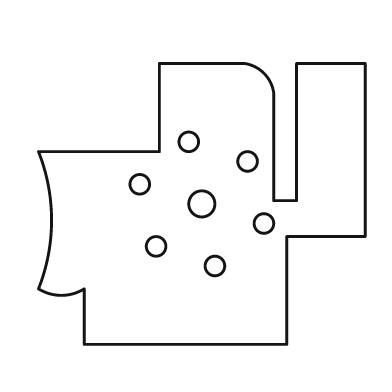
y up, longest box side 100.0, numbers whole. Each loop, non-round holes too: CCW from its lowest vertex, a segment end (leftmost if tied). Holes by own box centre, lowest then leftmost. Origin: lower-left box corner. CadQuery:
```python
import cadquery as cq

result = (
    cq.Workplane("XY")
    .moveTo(14.0, 0.0)
    .lineTo(76.0, 0.0)
    .lineTo(76.0, 33.0)
    .lineTo(100.0, 33.0)
    .lineTo(100.0, 86.0)
    .lineTo(79.0, 86.0)
    .lineTo(79.0, 44.0)
    .lineTo(72.0, 44.0)
    .lineTo(72.0, 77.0)
    .threePointArc((69.0, 83.0), (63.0, 86.0))
    .lineTo(37.0, 86.0)
    .lineTo(37.0, 59.0)
    .lineTo(0.0, 59.0)
    .threePointArc((4.0, 38.0), (0.0, 17.0))
    .threePointArc((7.0, 15.0), (14.0, 17.0))
    .close()
    .moveTo(54.0, 24.0)
    .circle(3.0)
    .moveTo(36.0, 30.0)
    .circle(3.0)
    .moveTo(69.0, 37.0)
    .circle(3.0)
    .moveTo(50.0, 43.0)
    .circle(4.0)
    .moveTo(31.0, 49.0)
    .circle(3.0)
    .moveTo(64.0, 56.0)
    .circle(3.0)
    .moveTo(46.0, 62.0)
    .circle(3.0)
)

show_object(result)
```